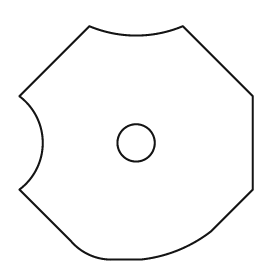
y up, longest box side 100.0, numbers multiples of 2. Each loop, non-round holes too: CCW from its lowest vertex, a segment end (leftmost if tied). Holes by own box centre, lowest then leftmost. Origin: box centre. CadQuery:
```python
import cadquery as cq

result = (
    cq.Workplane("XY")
    .moveTo(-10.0, -50.0)
    .lineTo(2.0, -50.0)
    .threePointArc((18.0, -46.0), (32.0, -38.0))
    .lineTo(50.0, -20.0)
    .lineTo(50.0, 20.0)
    .lineTo(20.0, 50.0)
    .threePointArc((0.0, 46.0), (-20.0, 50.0))
    .lineTo(-50.0, 20.0)
    .threePointArc((-40.0, 0.0), (-50.0, -20.0))
    .lineTo(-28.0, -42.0)
    .threePointArc((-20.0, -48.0), (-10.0, -50.0))
    .close()
    .moveTo(0.0, 0.0)
    .circle(8.0)
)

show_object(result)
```